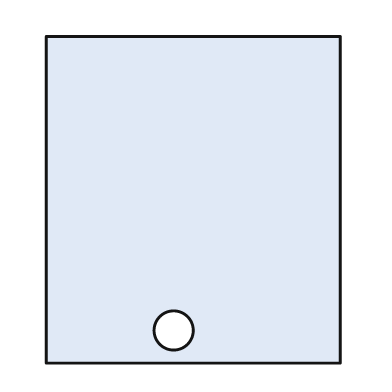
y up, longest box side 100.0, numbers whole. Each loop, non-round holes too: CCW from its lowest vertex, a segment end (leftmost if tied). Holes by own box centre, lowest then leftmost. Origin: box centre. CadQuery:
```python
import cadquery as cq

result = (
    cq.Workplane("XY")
    .moveTo(-45.0, -50.0)
    .lineTo(45.0, -50.0)
    .lineTo(45.0, 50.0)
    .lineTo(-45.0, 50.0)
    .close()
    .moveTo(-6.0, -40.0)
    .circle(6.0)
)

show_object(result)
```